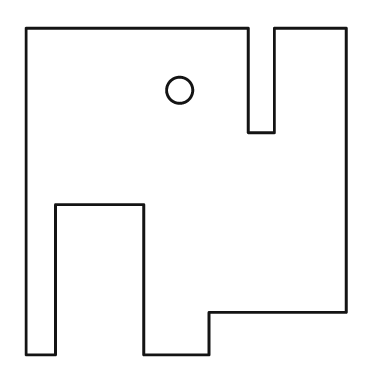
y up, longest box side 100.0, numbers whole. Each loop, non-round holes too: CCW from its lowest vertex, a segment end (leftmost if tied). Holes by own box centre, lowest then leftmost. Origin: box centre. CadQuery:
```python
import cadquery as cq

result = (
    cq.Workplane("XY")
    .moveTo(-49.0, -50.0)
    .lineTo(-40.0, -50.0)
    .lineTo(-40.0, -4.0)
    .lineTo(-13.0, -4.0)
    .lineTo(-13.0, -50.0)
    .lineTo(7.0, -50.0)
    .lineTo(7.0, -37.0)
    .lineTo(49.0, -37.0)
    .lineTo(49.0, 50.0)
    .lineTo(27.0, 50.0)
    .lineTo(27.0, 18.0)
    .lineTo(19.0, 18.0)
    .lineTo(19.0, 50.0)
    .lineTo(-49.0, 50.0)
    .close()
    .moveTo(-2.0, 31.0)
    .circle(4.0)
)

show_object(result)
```